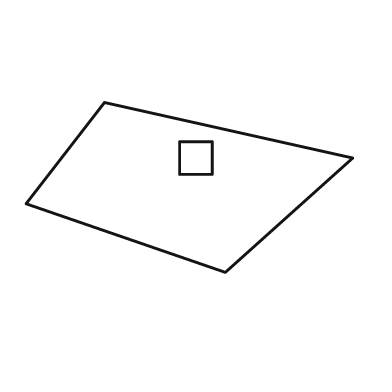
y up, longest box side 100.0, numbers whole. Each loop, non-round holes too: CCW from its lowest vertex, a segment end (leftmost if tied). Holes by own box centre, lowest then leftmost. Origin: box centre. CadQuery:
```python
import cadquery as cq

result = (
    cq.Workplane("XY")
    .moveTo(11.0, -26.0)
    .lineTo(50.0, 9.0)
    .lineTo(-26.0, 26.0)
    .lineTo(-50.0, -5.0)
    .close()
    .moveTo(-3.0, 4.0)
    .lineTo(7.0, 4.0)
    .lineTo(7.0, 14.0)
    .lineTo(-3.0, 14.0)
    .close()
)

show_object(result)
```